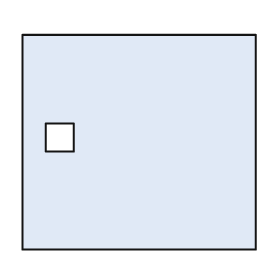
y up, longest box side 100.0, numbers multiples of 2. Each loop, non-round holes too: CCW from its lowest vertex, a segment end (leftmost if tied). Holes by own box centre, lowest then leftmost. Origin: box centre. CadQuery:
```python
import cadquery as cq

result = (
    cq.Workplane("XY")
    .moveTo(-50.0, -46.0)
    .lineTo(50.0, -46.0)
    .lineTo(50.0, 46.0)
    .lineTo(-50.0, 46.0)
    .close()
    .moveTo(-40.0, -4.0)
    .lineTo(-28.0, -4.0)
    .lineTo(-28.0, 8.0)
    .lineTo(-40.0, 8.0)
    .close()
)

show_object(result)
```